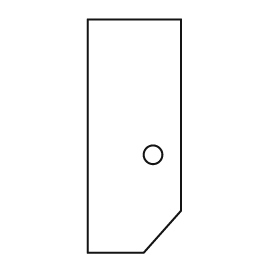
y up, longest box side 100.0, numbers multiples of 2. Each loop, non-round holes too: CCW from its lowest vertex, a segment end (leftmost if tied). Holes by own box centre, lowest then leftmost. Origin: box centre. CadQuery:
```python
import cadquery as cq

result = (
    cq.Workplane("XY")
    .moveTo(-20.0, -50.0)
    .lineTo(4.0, -50.0)
    .lineTo(20.0, -32.0)
    .lineTo(20.0, 50.0)
    .lineTo(-20.0, 50.0)
    .close()
    .moveTo(8.0, -8.0)
    .circle(4.0)
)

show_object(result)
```